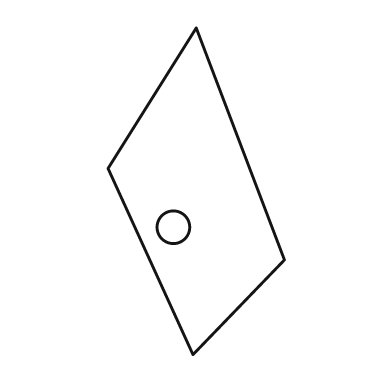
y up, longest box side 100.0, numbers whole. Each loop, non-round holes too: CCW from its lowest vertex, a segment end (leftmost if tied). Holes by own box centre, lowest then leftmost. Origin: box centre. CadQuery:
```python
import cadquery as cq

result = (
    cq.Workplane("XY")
    .moveTo(-1.0, -50.0)
    .lineTo(27.0, -21.0)
    .lineTo(0.0, 50.0)
    .lineTo(-27.0, 7.0)
    .close()
    .moveTo(-7.0, -11.0)
    .circle(5.0)
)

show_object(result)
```